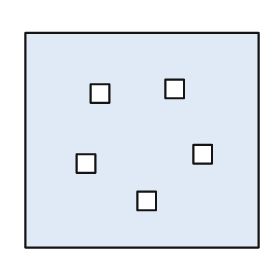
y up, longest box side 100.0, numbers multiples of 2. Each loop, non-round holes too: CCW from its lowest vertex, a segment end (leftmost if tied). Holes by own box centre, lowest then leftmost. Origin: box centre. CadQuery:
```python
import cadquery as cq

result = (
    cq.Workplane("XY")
    .moveTo(-50.0, -46.0)
    .lineTo(50.0, -46.0)
    .lineTo(50.0, 46.0)
    .lineTo(-50.0, 46.0)
    .close()
    .moveTo(-2.0, -30.0)
    .lineTo(6.0, -30.0)
    .lineTo(6.0, -22.0)
    .lineTo(-2.0, -22.0)
    .close()
    .moveTo(-28.0, -14.0)
    .lineTo(-20.0, -14.0)
    .lineTo(-20.0, -6.0)
    .lineTo(-28.0, -6.0)
    .close()
    .moveTo(22.0, -10.0)
    .lineTo(30.0, -10.0)
    .lineTo(30.0, -2.0)
    .lineTo(22.0, -2.0)
    .close()
    .moveTo(-22.0, 16.0)
    .lineTo(-14.0, 16.0)
    .lineTo(-14.0, 24.0)
    .lineTo(-22.0, 24.0)
    .close()
    .moveTo(10.0, 18.0)
    .lineTo(18.0, 18.0)
    .lineTo(18.0, 26.0)
    .lineTo(10.0, 26.0)
    .close()
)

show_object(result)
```